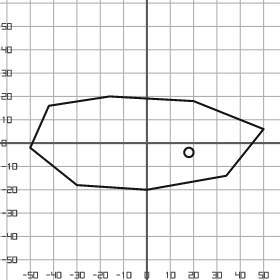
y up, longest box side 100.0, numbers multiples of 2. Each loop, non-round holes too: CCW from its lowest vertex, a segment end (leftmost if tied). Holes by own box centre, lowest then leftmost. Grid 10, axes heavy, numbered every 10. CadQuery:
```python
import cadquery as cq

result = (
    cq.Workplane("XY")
    .moveTo(0.0, -20.0)
    .lineTo(34.0, -14.0)
    .lineTo(50.0, 6.0)
    .lineTo(20.0, 18.0)
    .lineTo(-16.0, 20.0)
    .lineTo(-42.0, 16.0)
    .lineTo(-50.0, -2.0)
    .lineTo(-30.0, -18.0)
    .close()
    .moveTo(18.0, -4.0)
    .circle(2.0)
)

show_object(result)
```